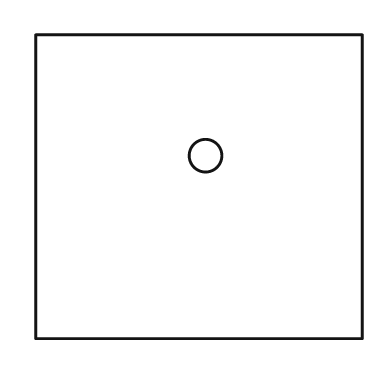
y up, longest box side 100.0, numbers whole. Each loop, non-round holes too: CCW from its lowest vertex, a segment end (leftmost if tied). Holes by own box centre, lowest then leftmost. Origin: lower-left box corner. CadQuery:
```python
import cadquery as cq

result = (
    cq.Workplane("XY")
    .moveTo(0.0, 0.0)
    .lineTo(100.0, 0.0)
    .lineTo(100.0, 93.0)
    .lineTo(0.0, 93.0)
    .close()
    .moveTo(52.0, 56.0)
    .circle(5.0)
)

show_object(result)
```